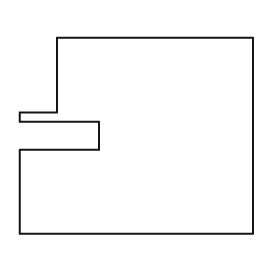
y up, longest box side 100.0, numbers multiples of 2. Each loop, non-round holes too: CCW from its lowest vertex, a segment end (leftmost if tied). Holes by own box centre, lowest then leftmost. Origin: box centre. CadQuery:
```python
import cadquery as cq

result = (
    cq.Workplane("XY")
    .moveTo(-50.0, -42.0)
    .lineTo(50.0, -42.0)
    .lineTo(50.0, 42.0)
    .lineTo(-34.0, 42.0)
    .lineTo(-34.0, 10.0)
    .lineTo(-50.0, 10.0)
    .lineTo(-50.0, 6.0)
    .lineTo(-16.0, 6.0)
    .lineTo(-16.0, -6.0)
    .lineTo(-50.0, -6.0)
    .close()
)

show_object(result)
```